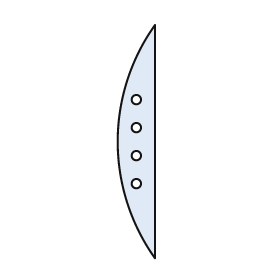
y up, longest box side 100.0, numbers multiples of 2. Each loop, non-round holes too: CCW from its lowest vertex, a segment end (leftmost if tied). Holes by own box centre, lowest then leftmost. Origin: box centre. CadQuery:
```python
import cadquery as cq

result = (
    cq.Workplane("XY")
    .moveTo(8.0, -50.0)
    .lineTo(8.0, 50.0)
    .threePointArc((-8.0, 0.0), (8.0, -50.0))
    .close()
    .moveTo(0.0, -18.0)
    .circle(2.0)
    .moveTo(0.0, -6.0)
    .circle(2.0)
    .moveTo(0.0, 6.0)
    .circle(2.0)
    .moveTo(0.0, 18.0)
    .circle(2.0)
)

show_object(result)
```